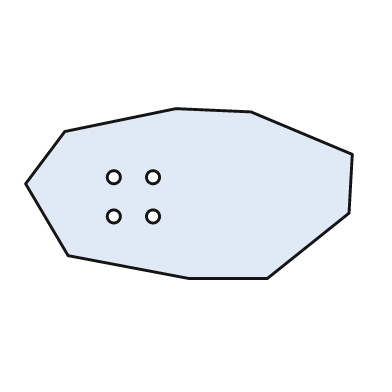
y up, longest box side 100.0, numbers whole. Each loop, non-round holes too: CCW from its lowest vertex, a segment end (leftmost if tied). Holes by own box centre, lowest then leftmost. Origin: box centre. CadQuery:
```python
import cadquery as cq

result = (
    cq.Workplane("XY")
    .moveTo(0.0, -26.0)
    .lineTo(24.0, -26.0)
    .lineTo(49.0, -6.0)
    .lineTo(50.0, 12.0)
    .lineTo(19.0, 25.0)
    .lineTo(-4.0, 26.0)
    .lineTo(-38.0, 19.0)
    .lineTo(-50.0, 3.0)
    .lineTo(-37.0, -19.0)
    .close()
    .moveTo(-23.0, -7.0)
    .circle(2.0)
    .moveTo(-11.0, -7.0)
    .circle(2.0)
    .moveTo(-23.0, 5.0)
    .circle(2.0)
    .moveTo(-11.0, 5.0)
    .circle(2.0)
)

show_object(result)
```